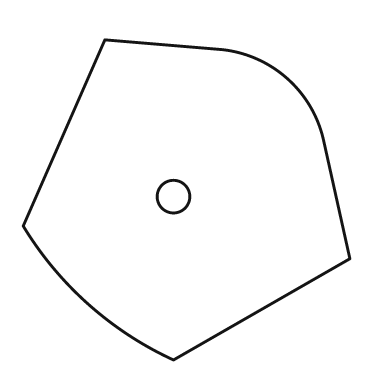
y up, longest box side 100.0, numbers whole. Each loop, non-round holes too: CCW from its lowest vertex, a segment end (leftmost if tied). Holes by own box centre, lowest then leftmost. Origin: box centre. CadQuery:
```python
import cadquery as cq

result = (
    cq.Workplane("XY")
    .moveTo(-4.0, -49.0)
    .lineTo(50.0, -18.0)
    .lineTo(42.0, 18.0)
    .threePointArc((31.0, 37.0), (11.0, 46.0))
    .lineTo(-25.0, 49.0)
    .lineTo(-50.0, -8.0)
    .threePointArc((-30.0, -32.0), (-4.0, -49.0))
    .close()
    .moveTo(-4.0, 1.0)
    .circle(5.0)
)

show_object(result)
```